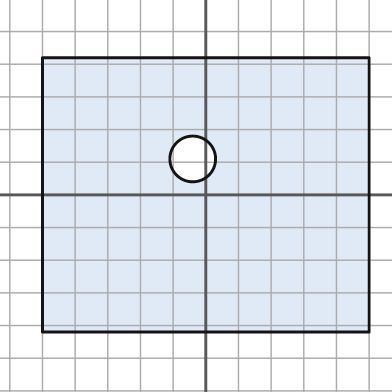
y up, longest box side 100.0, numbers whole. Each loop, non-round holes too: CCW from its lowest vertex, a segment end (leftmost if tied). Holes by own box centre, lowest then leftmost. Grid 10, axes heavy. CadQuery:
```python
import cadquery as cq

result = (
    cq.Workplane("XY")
    .moveTo(-50.0, -42.0)
    .lineTo(50.0, -42.0)
    .lineTo(50.0, 42.0)
    .lineTo(-50.0, 42.0)
    .close()
    .moveTo(-4.0, 11.0)
    .circle(7.0)
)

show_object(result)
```